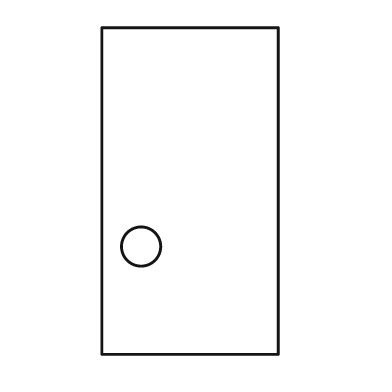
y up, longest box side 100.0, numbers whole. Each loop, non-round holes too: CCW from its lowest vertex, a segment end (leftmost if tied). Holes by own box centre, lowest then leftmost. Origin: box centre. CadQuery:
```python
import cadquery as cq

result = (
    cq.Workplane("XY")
    .moveTo(-27.0, -50.0)
    .lineTo(27.0, -50.0)
    .lineTo(27.0, 50.0)
    .lineTo(-27.0, 50.0)
    .close()
    .moveTo(-15.0, -17.0)
    .circle(6.0)
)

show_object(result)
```